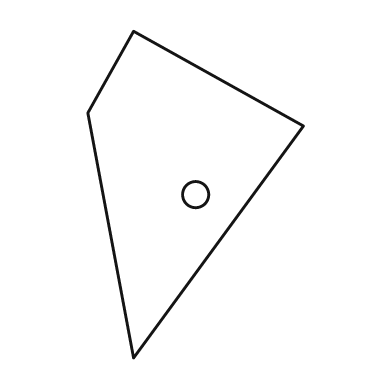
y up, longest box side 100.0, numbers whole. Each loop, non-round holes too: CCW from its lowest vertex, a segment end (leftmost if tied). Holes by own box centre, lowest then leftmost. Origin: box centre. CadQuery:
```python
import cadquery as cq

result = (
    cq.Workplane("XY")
    .moveTo(-19.0, -50.0)
    .lineTo(33.0, 21.0)
    .lineTo(-19.0, 50.0)
    .lineTo(-33.0, 25.0)
    .close()
    .moveTo(0.0, 0.0)
    .circle(4.0)
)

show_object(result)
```